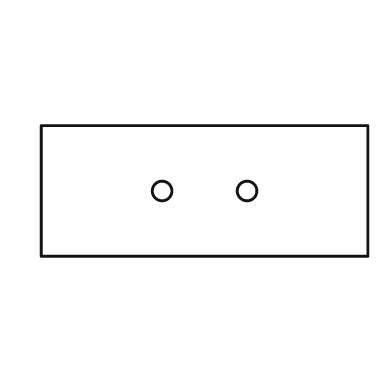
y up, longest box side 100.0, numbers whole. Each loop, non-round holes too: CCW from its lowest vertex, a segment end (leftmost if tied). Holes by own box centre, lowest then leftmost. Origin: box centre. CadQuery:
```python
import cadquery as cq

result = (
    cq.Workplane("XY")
    .moveTo(-50.0, -20.0)
    .lineTo(50.0, -20.0)
    .lineTo(50.0, 20.0)
    .lineTo(-50.0, 20.0)
    .close()
    .moveTo(-13.0, 0.0)
    .circle(3.0)
    .moveTo(13.0, 0.0)
    .circle(3.0)
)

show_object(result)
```